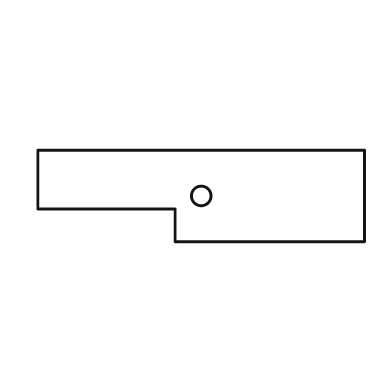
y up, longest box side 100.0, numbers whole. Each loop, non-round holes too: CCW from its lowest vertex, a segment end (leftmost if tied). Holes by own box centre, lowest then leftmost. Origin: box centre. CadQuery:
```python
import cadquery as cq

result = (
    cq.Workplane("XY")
    .moveTo(-8.0, -14.0)
    .lineTo(50.0, -14.0)
    .lineTo(50.0, 14.0)
    .lineTo(-50.0, 14.0)
    .lineTo(-50.0, -4.0)
    .lineTo(-8.0, -4.0)
    .close()
    .moveTo(0.0, 0.0)
    .circle(3.0)
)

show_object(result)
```